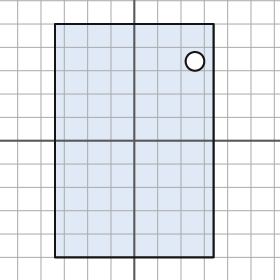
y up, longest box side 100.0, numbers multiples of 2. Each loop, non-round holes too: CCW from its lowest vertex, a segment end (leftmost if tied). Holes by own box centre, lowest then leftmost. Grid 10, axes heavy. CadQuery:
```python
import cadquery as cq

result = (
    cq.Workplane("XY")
    .moveTo(-34.0, -50.0)
    .lineTo(34.0, -50.0)
    .lineTo(34.0, 50.0)
    .lineTo(-34.0, 50.0)
    .close()
    .moveTo(26.0, 34.0)
    .circle(4.0)
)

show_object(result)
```